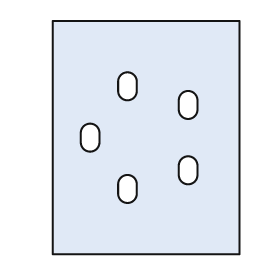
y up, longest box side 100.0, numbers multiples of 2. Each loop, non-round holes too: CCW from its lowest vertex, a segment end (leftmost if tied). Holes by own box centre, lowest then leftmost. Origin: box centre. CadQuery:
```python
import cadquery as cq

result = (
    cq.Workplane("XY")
    .moveTo(-40.0, -50.0)
    .lineTo(40.0, -50.0)
    .lineTo(40.0, 50.0)
    .lineTo(-40.0, 50.0)
    .close()
    .moveTo(-12.0, -24.0)
    .threePointArc((-8.0, -28.0), (-4.0, -24.0))
    .lineTo(-4.0, -20.0)
    .threePointArc((-8.0, -16.0), (-12.0, -20.0))
    .close()
    .moveTo(14.0, -16.0)
    .threePointArc((18.0, -20.0), (22.0, -16.0))
    .lineTo(22.0, -12.0)
    .threePointArc((18.0, -8.0), (14.0, -12.0))
    .close()
    .moveTo(-28.0, -2.0)
    .threePointArc((-24.0, -6.0), (-20.0, -2.0))
    .lineTo(-20.0, 2.0)
    .threePointArc((-24.0, 6.0), (-28.0, 2.0))
    .close()
    .moveTo(14.0, 12.0)
    .threePointArc((18.0, 8.0), (22.0, 12.0))
    .lineTo(22.0, 16.0)
    .threePointArc((18.0, 20.0), (14.0, 16.0))
    .close()
    .moveTo(-12.0, 20.0)
    .threePointArc((-8.0, 16.0), (-4.0, 20.0))
    .lineTo(-4.0, 24.0)
    .threePointArc((-8.0, 28.0), (-12.0, 24.0))
    .close()
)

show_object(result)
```